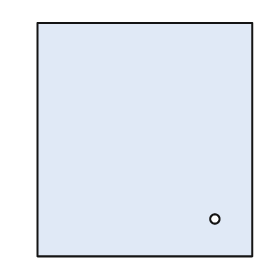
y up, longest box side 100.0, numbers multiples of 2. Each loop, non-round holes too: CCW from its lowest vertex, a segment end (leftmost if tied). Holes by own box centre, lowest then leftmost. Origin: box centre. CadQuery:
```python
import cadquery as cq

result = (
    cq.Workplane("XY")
    .moveTo(-46.0, -50.0)
    .lineTo(46.0, -50.0)
    .lineTo(46.0, 50.0)
    .lineTo(-46.0, 50.0)
    .close()
    .moveTo(30.0, -34.0)
    .circle(2.0)
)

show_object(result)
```